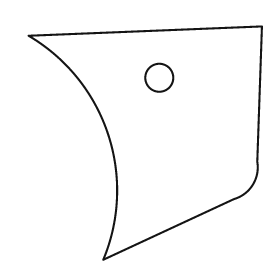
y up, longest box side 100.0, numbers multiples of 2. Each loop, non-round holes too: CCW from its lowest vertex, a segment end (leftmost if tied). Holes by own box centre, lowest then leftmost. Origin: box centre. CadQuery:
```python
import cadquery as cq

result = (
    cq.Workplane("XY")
    .moveTo(-18.0, -50.0)
    .lineTo(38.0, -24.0)
    .threePointArc((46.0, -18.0), (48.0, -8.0))
    .lineTo(50.0, 50.0)
    .lineTo(-50.0, 46.0)
    .threePointArc((-16.0, 4.0), (-18.0, -50.0))
    .close()
    .moveTo(6.0, 28.0)
    .circle(6.0)
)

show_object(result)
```